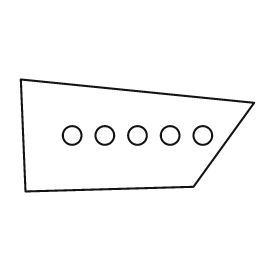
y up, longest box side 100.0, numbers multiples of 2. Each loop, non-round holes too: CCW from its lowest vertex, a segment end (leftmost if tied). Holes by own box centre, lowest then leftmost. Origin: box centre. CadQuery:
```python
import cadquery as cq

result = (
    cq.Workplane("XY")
    .moveTo(-48.0, -24.0)
    .lineTo(24.0, -22.0)
    .lineTo(50.0, 14.0)
    .lineTo(-50.0, 24.0)
    .close()
    .moveTo(-28.0, 0.0)
    .circle(4.0)
    .moveTo(-14.0, 0.0)
    .circle(4.0)
    .moveTo(0.0, 0.0)
    .circle(4.0)
    .moveTo(14.0, 0.0)
    .circle(4.0)
    .moveTo(28.0, 0.0)
    .circle(4.0)
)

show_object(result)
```